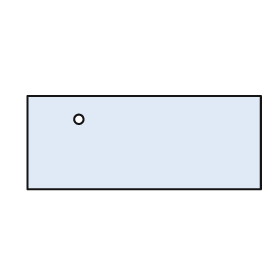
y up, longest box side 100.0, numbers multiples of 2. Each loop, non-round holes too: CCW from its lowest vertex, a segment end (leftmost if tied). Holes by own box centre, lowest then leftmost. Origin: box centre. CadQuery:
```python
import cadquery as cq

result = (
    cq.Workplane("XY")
    .moveTo(-50.0, -20.0)
    .lineTo(50.0, -20.0)
    .lineTo(50.0, 20.0)
    .lineTo(-50.0, 20.0)
    .close()
    .moveTo(-28.0, 10.0)
    .circle(2.0)
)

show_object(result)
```